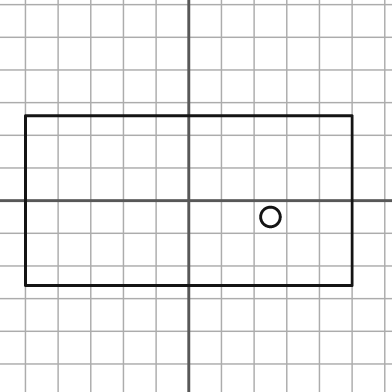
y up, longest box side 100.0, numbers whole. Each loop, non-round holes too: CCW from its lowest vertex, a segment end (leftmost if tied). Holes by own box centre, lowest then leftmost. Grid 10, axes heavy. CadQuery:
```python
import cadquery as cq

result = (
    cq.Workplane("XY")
    .moveTo(-50.0, -26.0)
    .lineTo(50.0, -26.0)
    .lineTo(50.0, 26.0)
    .lineTo(-50.0, 26.0)
    .close()
    .moveTo(25.0, -5.0)
    .circle(3.0)
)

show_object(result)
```